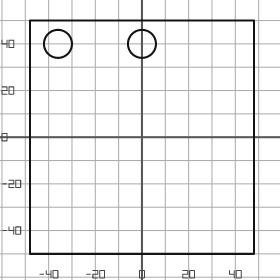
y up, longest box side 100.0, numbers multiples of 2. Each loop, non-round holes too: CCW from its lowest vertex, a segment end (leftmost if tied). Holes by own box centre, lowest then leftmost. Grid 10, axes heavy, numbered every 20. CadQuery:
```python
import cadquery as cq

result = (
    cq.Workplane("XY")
    .moveTo(-48.0, -50.0)
    .lineTo(48.0, -50.0)
    .lineTo(48.0, 50.0)
    .lineTo(-48.0, 50.0)
    .close()
    .moveTo(-36.0, 40.0)
    .circle(6.0)
    .moveTo(0.0, 40.0)
    .circle(6.0)
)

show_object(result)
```